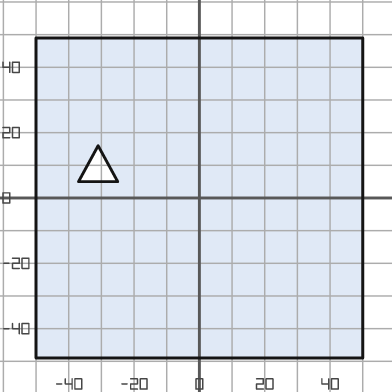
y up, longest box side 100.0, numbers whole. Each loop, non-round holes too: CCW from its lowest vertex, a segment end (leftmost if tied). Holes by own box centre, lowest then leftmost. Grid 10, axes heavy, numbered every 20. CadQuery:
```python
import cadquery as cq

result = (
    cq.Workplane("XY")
    .moveTo(-50.0, -49.0)
    .lineTo(50.0, -49.0)
    .lineTo(50.0, 49.0)
    .lineTo(-50.0, 49.0)
    .close()
    .moveTo(-37.0, 5.0)
    .lineTo(-25.0, 5.0)
    .lineTo(-31.0, 16.0)
    .close()
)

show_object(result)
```